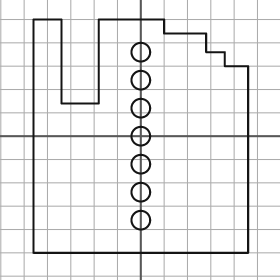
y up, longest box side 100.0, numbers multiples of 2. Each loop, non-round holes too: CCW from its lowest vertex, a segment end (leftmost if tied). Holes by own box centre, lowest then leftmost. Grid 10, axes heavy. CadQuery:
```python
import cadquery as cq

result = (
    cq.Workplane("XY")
    .moveTo(-46.0, -50.0)
    .lineTo(46.0, -50.0)
    .lineTo(46.0, 30.0)
    .lineTo(36.0, 30.0)
    .lineTo(36.0, 36.0)
    .lineTo(28.0, 36.0)
    .lineTo(28.0, 44.0)
    .lineTo(10.0, 44.0)
    .lineTo(10.0, 50.0)
    .lineTo(-18.0, 50.0)
    .lineTo(-18.0, 14.0)
    .lineTo(-34.0, 14.0)
    .lineTo(-34.0, 50.0)
    .lineTo(-46.0, 50.0)
    .close()
    .moveTo(0.0, -36.0)
    .circle(4.0)
    .moveTo(0.0, -24.0)
    .circle(4.0)
    .moveTo(0.0, -12.0)
    .circle(4.0)
    .moveTo(0.0, 0.0)
    .circle(4.0)
    .moveTo(0.0, 12.0)
    .circle(4.0)
    .moveTo(0.0, 24.0)
    .circle(4.0)
    .moveTo(0.0, 36.0)
    .circle(4.0)
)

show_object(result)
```